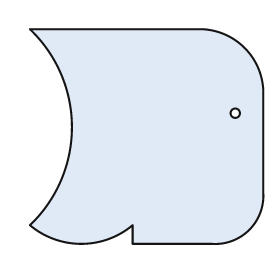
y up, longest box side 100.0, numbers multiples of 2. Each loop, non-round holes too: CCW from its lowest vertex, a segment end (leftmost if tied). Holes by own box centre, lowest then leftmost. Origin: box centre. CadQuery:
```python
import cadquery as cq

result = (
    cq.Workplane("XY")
    .moveTo(-6.0, -46.0)
    .lineTo(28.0, -46.0)
    .threePointArc((44.0, -40.0), (50.0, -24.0))
    .lineTo(50.0, 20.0)
    .threePointArc((42.0, 38.0), (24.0, 46.0))
    .lineTo(-50.0, 46.0)
    .threePointArc((-32.0, 4.0), (-50.0, -38.0))
    .threePointArc((-28.0, -46.0), (-6.0, -38.0))
    .close()
    .moveTo(38.0, 10.0)
    .circle(2.0)
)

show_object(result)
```